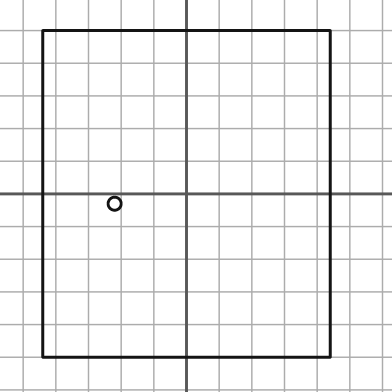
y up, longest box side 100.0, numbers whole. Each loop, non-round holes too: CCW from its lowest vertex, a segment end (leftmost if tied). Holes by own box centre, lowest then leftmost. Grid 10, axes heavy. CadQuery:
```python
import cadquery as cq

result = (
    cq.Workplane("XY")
    .moveTo(-44.0, -50.0)
    .lineTo(44.0, -50.0)
    .lineTo(44.0, 50.0)
    .lineTo(-44.0, 50.0)
    .close()
    .moveTo(-22.0, -3.0)
    .circle(2.0)
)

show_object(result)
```